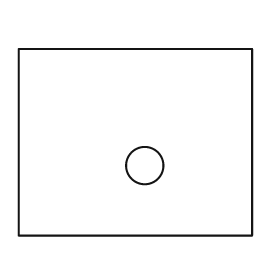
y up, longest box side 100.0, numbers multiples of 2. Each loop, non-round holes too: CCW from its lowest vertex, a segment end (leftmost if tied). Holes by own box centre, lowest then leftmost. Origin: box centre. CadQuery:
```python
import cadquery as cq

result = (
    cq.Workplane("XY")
    .moveTo(-50.0, -40.0)
    .lineTo(50.0, -40.0)
    .lineTo(50.0, 40.0)
    .lineTo(-50.0, 40.0)
    .close()
    .moveTo(4.0, -10.0)
    .circle(8.0)
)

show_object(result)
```